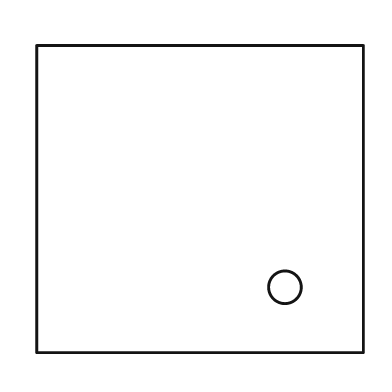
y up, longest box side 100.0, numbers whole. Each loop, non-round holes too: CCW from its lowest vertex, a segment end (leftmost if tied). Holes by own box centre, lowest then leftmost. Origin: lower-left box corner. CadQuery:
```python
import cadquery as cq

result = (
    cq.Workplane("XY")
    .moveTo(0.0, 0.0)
    .lineTo(100.0, 0.0)
    .lineTo(100.0, 94.0)
    .lineTo(0.0, 94.0)
    .close()
    .moveTo(76.0, 20.0)
    .circle(5.0)
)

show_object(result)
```